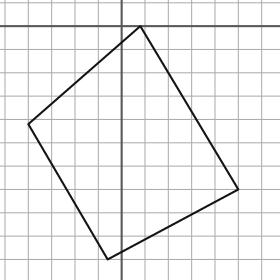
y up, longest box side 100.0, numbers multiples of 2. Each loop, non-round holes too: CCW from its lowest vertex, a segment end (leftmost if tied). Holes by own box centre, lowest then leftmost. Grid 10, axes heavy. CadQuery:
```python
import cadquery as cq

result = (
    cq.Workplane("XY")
    .moveTo(-6.0, -100.0)
    .lineTo(50.0, -70.0)
    .lineTo(8.0, 0.0)
    .lineTo(-40.0, -42.0)
    .close()
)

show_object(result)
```